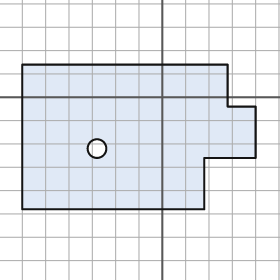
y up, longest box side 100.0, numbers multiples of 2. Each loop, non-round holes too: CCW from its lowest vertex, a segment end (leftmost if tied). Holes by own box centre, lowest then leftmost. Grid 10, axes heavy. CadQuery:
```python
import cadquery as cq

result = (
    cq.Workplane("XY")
    .moveTo(-60.0, -48.0)
    .lineTo(18.0, -48.0)
    .lineTo(18.0, -26.0)
    .lineTo(40.0, -26.0)
    .lineTo(40.0, -4.0)
    .lineTo(28.0, -4.0)
    .lineTo(28.0, 14.0)
    .lineTo(-60.0, 14.0)
    .close()
    .moveTo(-28.0, -22.0)
    .circle(4.0)
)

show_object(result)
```